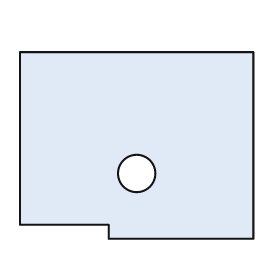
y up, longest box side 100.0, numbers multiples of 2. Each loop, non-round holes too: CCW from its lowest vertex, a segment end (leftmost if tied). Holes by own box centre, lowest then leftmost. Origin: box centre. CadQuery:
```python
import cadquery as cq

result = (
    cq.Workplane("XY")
    .moveTo(-12.0, -40.0)
    .lineTo(50.0, -40.0)
    .lineTo(50.0, 40.0)
    .lineTo(-50.0, 40.0)
    .lineTo(-50.0, -34.0)
    .lineTo(-12.0, -34.0)
    .close()
    .moveTo(0.0, -12.0)
    .circle(8.0)
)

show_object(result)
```